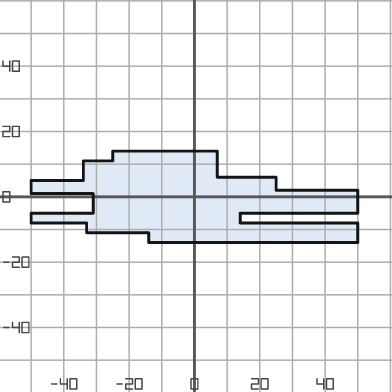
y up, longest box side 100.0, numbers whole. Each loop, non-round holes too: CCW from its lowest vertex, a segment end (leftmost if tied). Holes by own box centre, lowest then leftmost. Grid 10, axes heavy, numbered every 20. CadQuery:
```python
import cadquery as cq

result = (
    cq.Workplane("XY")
    .moveTo(-14.0, -14.0)
    .lineTo(50.0, -14.0)
    .lineTo(50.0, -8.0)
    .lineTo(14.0, -8.0)
    .lineTo(14.0, -5.0)
    .lineTo(50.0, -5.0)
    .lineTo(50.0, 2.0)
    .lineTo(25.0, 2.0)
    .lineTo(25.0, 6.0)
    .lineTo(7.0, 6.0)
    .lineTo(7.0, 14.0)
    .lineTo(-25.0, 14.0)
    .lineTo(-25.0, 11.0)
    .lineTo(-34.0, 11.0)
    .lineTo(-34.0, 5.0)
    .lineTo(-50.0, 5.0)
    .lineTo(-50.0, 1.0)
    .lineTo(-31.0, 1.0)
    .lineTo(-31.0, -5.0)
    .lineTo(-50.0, -5.0)
    .lineTo(-50.0, -8.0)
    .lineTo(-33.0, -8.0)
    .lineTo(-33.0, -11.0)
    .lineTo(-14.0, -11.0)
    .close()
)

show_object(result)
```